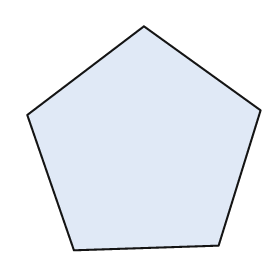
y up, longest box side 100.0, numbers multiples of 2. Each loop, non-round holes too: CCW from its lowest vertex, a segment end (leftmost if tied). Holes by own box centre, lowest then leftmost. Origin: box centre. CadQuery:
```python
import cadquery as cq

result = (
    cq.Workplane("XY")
    .moveTo(-30.0, -48.0)
    .lineTo(32.0, -46.0)
    .lineTo(50.0, 12.0)
    .lineTo(0.0, 48.0)
    .lineTo(-50.0, 10.0)
    .close()
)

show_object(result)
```